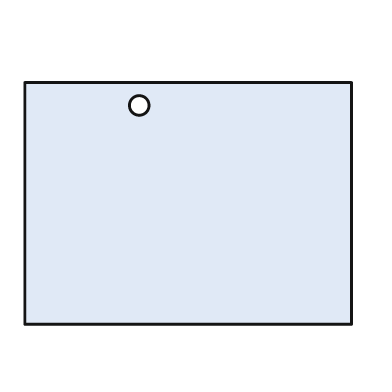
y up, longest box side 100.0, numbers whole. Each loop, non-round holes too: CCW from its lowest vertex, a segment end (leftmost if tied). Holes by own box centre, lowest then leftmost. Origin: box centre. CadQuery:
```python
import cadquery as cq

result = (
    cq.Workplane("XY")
    .moveTo(-50.0, -37.0)
    .lineTo(50.0, -37.0)
    .lineTo(50.0, 37.0)
    .lineTo(-50.0, 37.0)
    .close()
    .moveTo(-15.0, 30.0)
    .circle(3.0)
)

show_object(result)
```